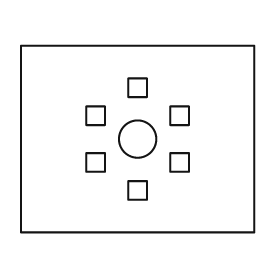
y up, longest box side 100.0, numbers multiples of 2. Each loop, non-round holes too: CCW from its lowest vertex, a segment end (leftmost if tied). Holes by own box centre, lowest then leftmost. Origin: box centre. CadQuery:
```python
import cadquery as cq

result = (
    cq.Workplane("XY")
    .moveTo(-50.0, -40.0)
    .lineTo(50.0, -40.0)
    .lineTo(50.0, 40.0)
    .lineTo(-50.0, 40.0)
    .close()
    .moveTo(-4.0, -26.0)
    .lineTo(4.0, -26.0)
    .lineTo(4.0, -18.0)
    .lineTo(-4.0, -18.0)
    .close()
    .moveTo(-22.0, -14.0)
    .lineTo(-14.0, -14.0)
    .lineTo(-14.0, -6.0)
    .lineTo(-22.0, -6.0)
    .close()
    .moveTo(14.0, -14.0)
    .lineTo(22.0, -14.0)
    .lineTo(22.0, -6.0)
    .lineTo(14.0, -6.0)
    .close()
    .moveTo(0.0, 0.0)
    .circle(8.0)
    .moveTo(-22.0, 6.0)
    .lineTo(-14.0, 6.0)
    .lineTo(-14.0, 14.0)
    .lineTo(-22.0, 14.0)
    .close()
    .moveTo(14.0, 6.0)
    .lineTo(22.0, 6.0)
    .lineTo(22.0, 14.0)
    .lineTo(14.0, 14.0)
    .close()
    .moveTo(-4.0, 18.0)
    .lineTo(4.0, 18.0)
    .lineTo(4.0, 26.0)
    .lineTo(-4.0, 26.0)
    .close()
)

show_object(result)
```